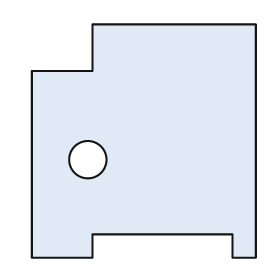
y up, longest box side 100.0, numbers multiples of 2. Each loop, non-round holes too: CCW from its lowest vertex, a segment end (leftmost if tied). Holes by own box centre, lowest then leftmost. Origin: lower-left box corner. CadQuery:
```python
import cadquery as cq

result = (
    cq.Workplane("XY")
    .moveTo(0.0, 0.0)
    .lineTo(26.0, 0.0)
    .lineTo(26.0, 10.0)
    .lineTo(86.0, 10.0)
    .lineTo(86.0, 0.0)
    .lineTo(96.0, 0.0)
    .lineTo(96.0, 100.0)
    .lineTo(26.0, 100.0)
    .lineTo(26.0, 80.0)
    .lineTo(0.0, 80.0)
    .close()
    .moveTo(24.0, 42.0)
    .circle(8.0)
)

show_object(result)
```